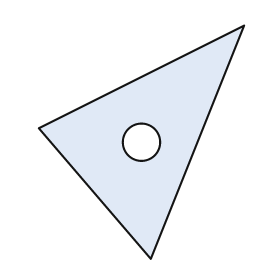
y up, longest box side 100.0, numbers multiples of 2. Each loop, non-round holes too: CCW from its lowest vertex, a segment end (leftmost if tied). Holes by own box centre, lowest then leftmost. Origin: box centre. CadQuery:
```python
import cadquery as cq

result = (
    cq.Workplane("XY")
    .moveTo(4.0, -50.0)
    .lineTo(44.0, 50.0)
    .lineTo(-44.0, 6.0)
    .close()
    .moveTo(0.0, 0.0)
    .circle(8.0)
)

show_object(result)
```